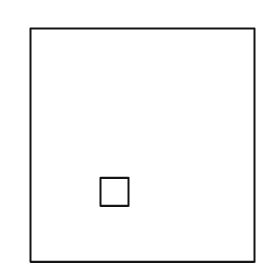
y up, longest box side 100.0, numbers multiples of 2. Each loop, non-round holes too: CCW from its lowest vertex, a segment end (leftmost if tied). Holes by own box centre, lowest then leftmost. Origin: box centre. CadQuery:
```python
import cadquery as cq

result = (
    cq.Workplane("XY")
    .moveTo(-48.0, -50.0)
    .lineTo(48.0, -50.0)
    .lineTo(48.0, 50.0)
    .lineTo(-48.0, 50.0)
    .close()
    .moveTo(-18.0, -26.0)
    .lineTo(-6.0, -26.0)
    .lineTo(-6.0, -14.0)
    .lineTo(-18.0, -14.0)
    .close()
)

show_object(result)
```